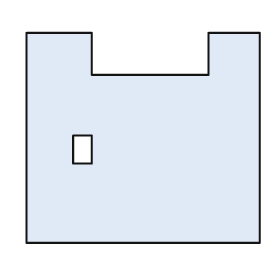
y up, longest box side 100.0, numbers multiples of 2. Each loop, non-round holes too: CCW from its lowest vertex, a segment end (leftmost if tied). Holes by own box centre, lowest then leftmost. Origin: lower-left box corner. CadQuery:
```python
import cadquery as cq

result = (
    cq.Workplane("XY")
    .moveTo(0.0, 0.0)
    .lineTo(100.0, 0.0)
    .lineTo(100.0, 90.0)
    .lineTo(78.0, 90.0)
    .lineTo(78.0, 72.0)
    .lineTo(28.0, 72.0)
    .lineTo(28.0, 90.0)
    .lineTo(0.0, 90.0)
    .close()
    .moveTo(20.0, 34.0)
    .lineTo(28.0, 34.0)
    .lineTo(28.0, 46.0)
    .lineTo(20.0, 46.0)
    .close()
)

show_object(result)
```